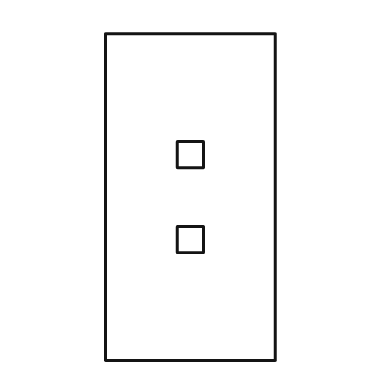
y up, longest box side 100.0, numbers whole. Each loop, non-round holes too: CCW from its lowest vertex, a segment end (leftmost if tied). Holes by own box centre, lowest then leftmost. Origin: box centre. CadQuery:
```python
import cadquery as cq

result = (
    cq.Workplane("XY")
    .moveTo(-26.0, -50.0)
    .lineTo(26.0, -50.0)
    .lineTo(26.0, 50.0)
    .lineTo(-26.0, 50.0)
    .close()
    .moveTo(-4.0, -17.0)
    .lineTo(4.0, -17.0)
    .lineTo(4.0, -9.0)
    .lineTo(-4.0, -9.0)
    .close()
    .moveTo(-4.0, 9.0)
    .lineTo(4.0, 9.0)
    .lineTo(4.0, 17.0)
    .lineTo(-4.0, 17.0)
    .close()
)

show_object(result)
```